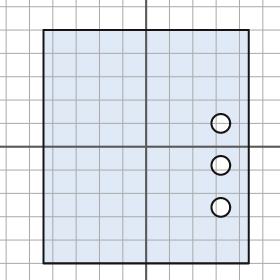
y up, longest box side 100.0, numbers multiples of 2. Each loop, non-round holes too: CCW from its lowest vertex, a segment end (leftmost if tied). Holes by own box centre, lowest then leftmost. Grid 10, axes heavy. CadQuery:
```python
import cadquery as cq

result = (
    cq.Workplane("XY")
    .moveTo(-44.0, -50.0)
    .lineTo(44.0, -50.0)
    .lineTo(44.0, 50.0)
    .lineTo(-44.0, 50.0)
    .close()
    .moveTo(32.0, -26.0)
    .circle(4.0)
    .moveTo(32.0, -8.0)
    .circle(4.0)
    .moveTo(32.0, 10.0)
    .circle(4.0)
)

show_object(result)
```